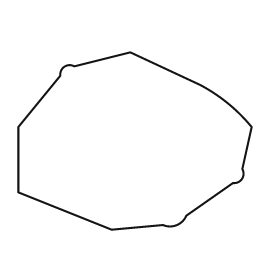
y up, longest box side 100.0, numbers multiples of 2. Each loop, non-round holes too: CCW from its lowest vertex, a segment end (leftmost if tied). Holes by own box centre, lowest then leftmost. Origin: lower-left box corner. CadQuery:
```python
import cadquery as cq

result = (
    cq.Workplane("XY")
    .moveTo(40.0, 0.0)
    .lineTo(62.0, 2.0)
    .threePointArc((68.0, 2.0), (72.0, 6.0))
    .lineTo(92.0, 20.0)
    .threePointArc((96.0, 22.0), (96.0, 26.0))
    .lineTo(100.0, 44.0)
    .threePointArc((90.0, 54.0), (78.0, 62.0))
    .lineTo(48.0, 76.0)
    .lineTo(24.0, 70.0)
    .threePointArc((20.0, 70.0), (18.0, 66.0))
    .lineTo(0.0, 44.0)
    .lineTo(0.0, 16.0)
    .close()
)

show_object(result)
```